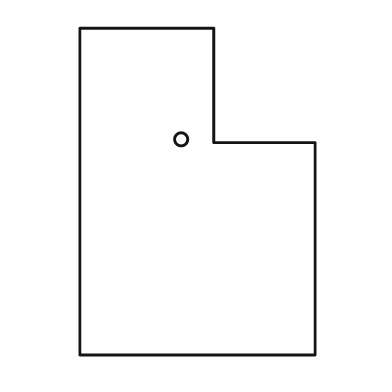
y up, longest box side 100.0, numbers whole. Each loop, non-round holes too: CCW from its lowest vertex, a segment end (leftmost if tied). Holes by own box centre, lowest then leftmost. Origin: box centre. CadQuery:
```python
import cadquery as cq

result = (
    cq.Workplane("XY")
    .moveTo(-36.0, -50.0)
    .lineTo(36.0, -50.0)
    .lineTo(36.0, 15.0)
    .lineTo(5.0, 15.0)
    .lineTo(5.0, 50.0)
    .lineTo(-36.0, 50.0)
    .close()
    .moveTo(-5.0, 16.0)
    .circle(2.0)
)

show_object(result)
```